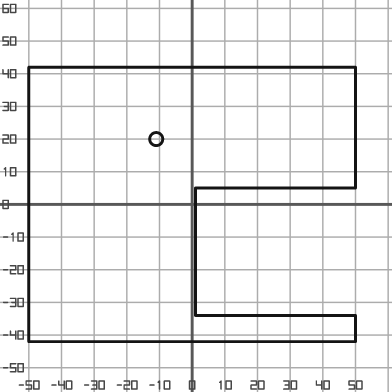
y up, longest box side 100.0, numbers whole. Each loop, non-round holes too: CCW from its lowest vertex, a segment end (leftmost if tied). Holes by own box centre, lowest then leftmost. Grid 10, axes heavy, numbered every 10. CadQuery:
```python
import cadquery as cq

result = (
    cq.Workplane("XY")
    .moveTo(-50.0, -42.0)
    .lineTo(50.0, -42.0)
    .lineTo(50.0, -34.0)
    .lineTo(1.0, -34.0)
    .lineTo(1.0, 5.0)
    .lineTo(50.0, 5.0)
    .lineTo(50.0, 42.0)
    .lineTo(-50.0, 42.0)
    .close()
    .moveTo(-11.0, 20.0)
    .circle(2.0)
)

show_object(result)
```